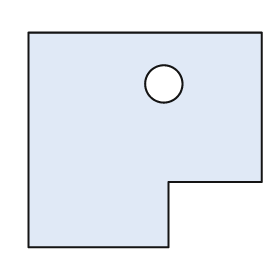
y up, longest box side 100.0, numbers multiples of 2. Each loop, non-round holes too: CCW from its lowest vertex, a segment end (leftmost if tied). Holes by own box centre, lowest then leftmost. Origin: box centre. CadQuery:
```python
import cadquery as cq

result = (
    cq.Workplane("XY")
    .moveTo(-50.0, -46.0)
    .lineTo(10.0, -46.0)
    .lineTo(10.0, -18.0)
    .lineTo(50.0, -18.0)
    .lineTo(50.0, 46.0)
    .lineTo(-50.0, 46.0)
    .close()
    .moveTo(8.0, 24.0)
    .circle(8.0)
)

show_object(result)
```